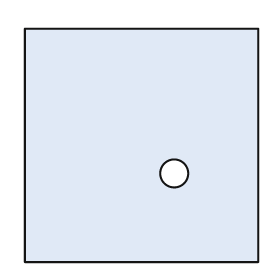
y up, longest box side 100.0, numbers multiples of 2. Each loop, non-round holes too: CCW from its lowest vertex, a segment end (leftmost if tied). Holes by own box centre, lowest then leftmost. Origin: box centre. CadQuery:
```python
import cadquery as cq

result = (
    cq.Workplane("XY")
    .moveTo(-50.0, -50.0)
    .lineTo(50.0, -50.0)
    .lineTo(50.0, 50.0)
    .lineTo(-50.0, 50.0)
    .close()
    .moveTo(14.0, -12.0)
    .circle(6.0)
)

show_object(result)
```